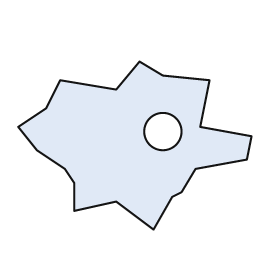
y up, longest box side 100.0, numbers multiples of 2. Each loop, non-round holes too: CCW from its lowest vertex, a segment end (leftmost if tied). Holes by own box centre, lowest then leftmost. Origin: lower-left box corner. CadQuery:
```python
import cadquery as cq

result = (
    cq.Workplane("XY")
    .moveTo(58.0, 0.0)
    .lineTo(66.0, 14.0)
    .lineTo(70.0, 16.0)
    .lineTo(76.0, 26.0)
    .lineTo(98.0, 30.0)
    .lineTo(100.0, 40.0)
    .lineTo(78.0, 44.0)
    .lineTo(82.0, 64.0)
    .lineTo(62.0, 66.0)
    .lineTo(52.0, 72.0)
    .lineTo(42.0, 60.0)
    .lineTo(18.0, 64.0)
    .lineTo(12.0, 52.0)
    .lineTo(0.0, 44.0)
    .lineTo(8.0, 34.0)
    .lineTo(20.0, 26.0)
    .lineTo(24.0, 20.0)
    .lineTo(24.0, 8.0)
    .lineTo(42.0, 12.0)
    .close()
    .moveTo(62.0, 42.0)
    .circle(8.0)
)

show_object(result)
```